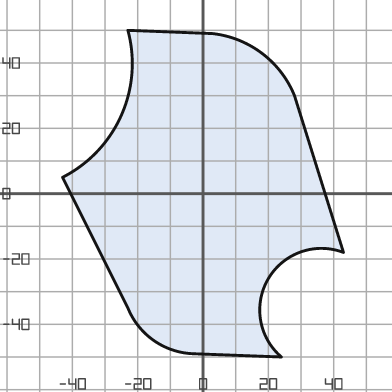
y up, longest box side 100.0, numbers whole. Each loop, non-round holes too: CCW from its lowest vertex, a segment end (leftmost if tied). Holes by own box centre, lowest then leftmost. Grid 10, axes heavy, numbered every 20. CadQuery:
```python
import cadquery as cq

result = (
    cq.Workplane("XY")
    .moveTo(24.0, -50.0)
    .threePointArc((20.0, -26.0), (43.0, -18.0))
    .lineTo(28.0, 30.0)
    .threePointArc((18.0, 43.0), (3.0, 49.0))
    .lineTo(-23.0, 50.0)
    .threePointArc((-25.0, 24.0), (-43.0, 5.0))
    .lineTo(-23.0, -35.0)
    .threePointArc((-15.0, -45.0), (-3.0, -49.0))
    .close()
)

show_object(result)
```